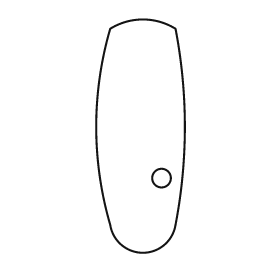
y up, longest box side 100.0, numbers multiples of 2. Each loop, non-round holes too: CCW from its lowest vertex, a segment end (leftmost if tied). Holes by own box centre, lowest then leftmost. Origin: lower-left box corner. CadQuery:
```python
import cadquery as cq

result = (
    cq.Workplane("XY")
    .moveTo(6.0, 12.0)
    .threePointArc((20.0, 0.0), (34.0, 12.0))
    .threePointArc((38.0, 54.0), (34.0, 96.0))
    .threePointArc((20.0, 100.0), (6.0, 96.0))
    .threePointArc((0.0, 54.0), (6.0, 12.0))
    .close()
    .moveTo(28.0, 32.0)
    .circle(4.0)
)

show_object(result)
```